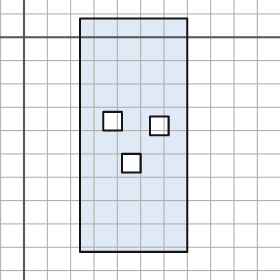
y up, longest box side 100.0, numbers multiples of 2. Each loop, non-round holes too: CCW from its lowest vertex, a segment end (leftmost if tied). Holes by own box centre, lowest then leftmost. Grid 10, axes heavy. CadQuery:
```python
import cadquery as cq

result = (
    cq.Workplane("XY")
    .moveTo(24.0, -92.0)
    .lineTo(70.0, -92.0)
    .lineTo(70.0, 8.0)
    .lineTo(24.0, 8.0)
    .close()
    .moveTo(42.0, -58.0)
    .lineTo(50.0, -58.0)
    .lineTo(50.0, -50.0)
    .lineTo(42.0, -50.0)
    .close()
    .moveTo(54.0, -42.0)
    .lineTo(62.0, -42.0)
    .lineTo(62.0, -34.0)
    .lineTo(54.0, -34.0)
    .close()
    .moveTo(34.0, -40.0)
    .lineTo(42.0, -40.0)
    .lineTo(42.0, -32.0)
    .lineTo(34.0, -32.0)
    .close()
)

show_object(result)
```